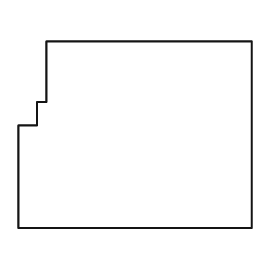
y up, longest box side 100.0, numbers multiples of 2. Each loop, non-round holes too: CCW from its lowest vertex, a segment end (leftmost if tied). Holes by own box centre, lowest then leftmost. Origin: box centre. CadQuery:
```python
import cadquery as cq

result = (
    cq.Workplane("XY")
    .moveTo(-50.0, -40.0)
    .lineTo(50.0, -40.0)
    .lineTo(50.0, 40.0)
    .lineTo(-38.0, 40.0)
    .lineTo(-38.0, 14.0)
    .lineTo(-42.0, 14.0)
    .lineTo(-42.0, 4.0)
    .lineTo(-50.0, 4.0)
    .close()
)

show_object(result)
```